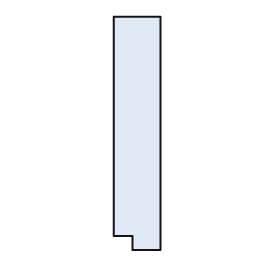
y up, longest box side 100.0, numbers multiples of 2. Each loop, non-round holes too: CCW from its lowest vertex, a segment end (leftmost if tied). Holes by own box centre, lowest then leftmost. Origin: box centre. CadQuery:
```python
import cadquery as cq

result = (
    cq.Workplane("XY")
    .moveTo(-2.0, -50.0)
    .lineTo(10.0, -50.0)
    .lineTo(10.0, 50.0)
    .lineTo(-10.0, 50.0)
    .lineTo(-10.0, -44.0)
    .lineTo(-2.0, -44.0)
    .close()
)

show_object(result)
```